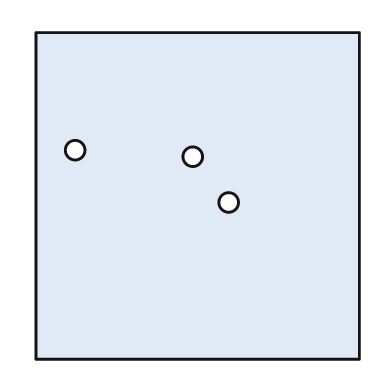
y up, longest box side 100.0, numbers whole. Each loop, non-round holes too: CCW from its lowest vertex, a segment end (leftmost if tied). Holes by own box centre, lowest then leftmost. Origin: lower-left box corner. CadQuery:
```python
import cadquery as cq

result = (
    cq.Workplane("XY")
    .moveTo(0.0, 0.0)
    .lineTo(99.0, 0.0)
    .lineTo(99.0, 100.0)
    .lineTo(0.0, 100.0)
    .close()
    .moveTo(59.0, 48.0)
    .circle(3.0)
    .moveTo(48.0, 62.0)
    .circle(3.0)
    .moveTo(12.0, 64.0)
    .circle(3.0)
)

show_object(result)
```